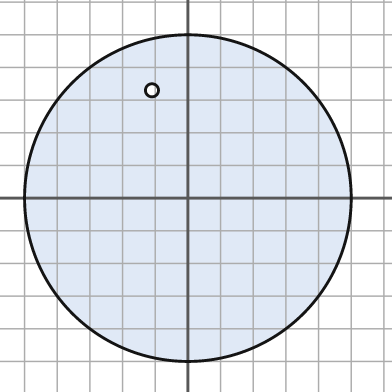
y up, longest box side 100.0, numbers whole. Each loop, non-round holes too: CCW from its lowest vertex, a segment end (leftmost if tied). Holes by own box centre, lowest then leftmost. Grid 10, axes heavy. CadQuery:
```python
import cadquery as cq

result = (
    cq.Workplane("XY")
    .moveTo(0.0, 0.0)
    .circle(50.0)
    .moveTo(-11.0, 33.0)
    .circle(2.0)
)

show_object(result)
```